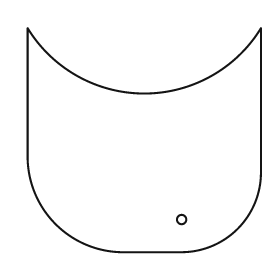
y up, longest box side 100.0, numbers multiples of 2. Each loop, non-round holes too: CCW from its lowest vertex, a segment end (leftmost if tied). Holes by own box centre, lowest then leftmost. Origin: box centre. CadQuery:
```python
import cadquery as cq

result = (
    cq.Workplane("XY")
    .moveTo(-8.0, -48.0)
    .lineTo(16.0, -48.0)
    .threePointArc((40.0, -38.0), (50.0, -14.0))
    .lineTo(50.0, 48.0)
    .threePointArc((0.0, 20.0), (-50.0, 48.0))
    .lineTo(-50.0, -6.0)
    .threePointArc((-38.0, -36.0), (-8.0, -48.0))
    .close()
    .moveTo(16.0, -34.0)
    .circle(2.0)
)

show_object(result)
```